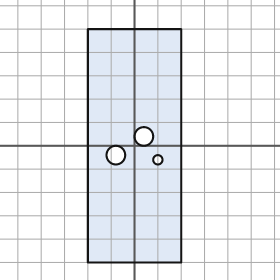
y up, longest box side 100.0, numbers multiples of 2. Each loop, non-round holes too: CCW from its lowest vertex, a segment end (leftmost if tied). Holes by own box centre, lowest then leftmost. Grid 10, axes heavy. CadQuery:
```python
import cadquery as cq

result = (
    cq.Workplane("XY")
    .moveTo(-20.0, -50.0)
    .lineTo(20.0, -50.0)
    .lineTo(20.0, 50.0)
    .lineTo(-20.0, 50.0)
    .close()
    .moveTo(10.0, -6.0)
    .circle(2.0)
    .moveTo(-8.0, -4.0)
    .circle(4.0)
    .moveTo(4.0, 4.0)
    .circle(4.0)
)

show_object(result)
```